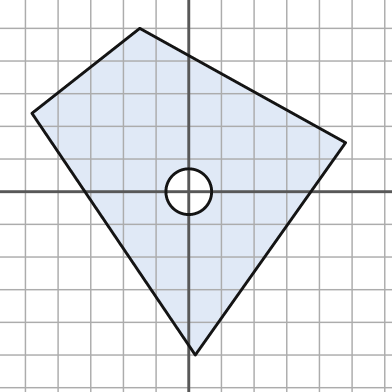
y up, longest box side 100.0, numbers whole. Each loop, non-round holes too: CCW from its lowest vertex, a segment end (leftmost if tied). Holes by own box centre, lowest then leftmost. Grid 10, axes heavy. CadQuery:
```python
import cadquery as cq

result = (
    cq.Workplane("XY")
    .moveTo(2.0, -50.0)
    .lineTo(48.0, 15.0)
    .lineTo(-15.0, 50.0)
    .lineTo(-48.0, 24.0)
    .close()
    .moveTo(0.0, 0.0)
    .circle(7.0)
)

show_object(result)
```